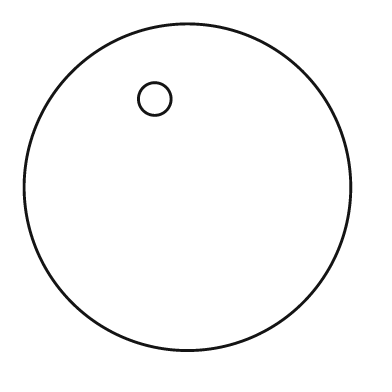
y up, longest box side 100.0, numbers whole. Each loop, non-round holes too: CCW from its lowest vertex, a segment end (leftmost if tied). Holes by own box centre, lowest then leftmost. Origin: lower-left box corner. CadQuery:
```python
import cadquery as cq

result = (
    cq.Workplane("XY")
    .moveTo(50.0, 50.0)
    .circle(50.0)
    .moveTo(40.0, 77.0)
    .circle(5.0)
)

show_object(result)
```